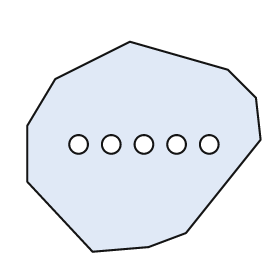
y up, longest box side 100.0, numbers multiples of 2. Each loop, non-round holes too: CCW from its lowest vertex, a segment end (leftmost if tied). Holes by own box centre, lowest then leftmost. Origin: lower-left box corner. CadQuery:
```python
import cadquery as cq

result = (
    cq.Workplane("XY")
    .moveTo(28.0, 0.0)
    .lineTo(52.0, 2.0)
    .lineTo(68.0, 8.0)
    .lineTo(100.0, 48.0)
    .lineTo(98.0, 66.0)
    .lineTo(86.0, 78.0)
    .lineTo(44.0, 90.0)
    .lineTo(12.0, 74.0)
    .lineTo(0.0, 54.0)
    .lineTo(0.0, 30.0)
    .close()
    .moveTo(22.0, 46.0)
    .circle(4.0)
    .moveTo(36.0, 46.0)
    .circle(4.0)
    .moveTo(50.0, 46.0)
    .circle(4.0)
    .moveTo(64.0, 46.0)
    .circle(4.0)
    .moveTo(78.0, 46.0)
    .circle(4.0)
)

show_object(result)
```